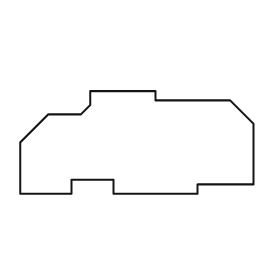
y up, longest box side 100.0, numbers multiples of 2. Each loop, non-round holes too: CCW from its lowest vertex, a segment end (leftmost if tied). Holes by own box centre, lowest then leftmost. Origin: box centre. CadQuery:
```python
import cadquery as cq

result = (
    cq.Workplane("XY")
    .moveTo(-50.0, -22.0)
    .lineTo(-28.0, -22.0)
    .lineTo(-28.0, -16.0)
    .lineTo(-10.0, -16.0)
    .lineTo(-10.0, -22.0)
    .lineTo(26.0, -22.0)
    .lineTo(26.0, -18.0)
    .lineTo(50.0, -18.0)
    .lineTo(50.0, 8.0)
    .lineTo(40.0, 18.0)
    .lineTo(8.0, 18.0)
    .lineTo(8.0, 22.0)
    .lineTo(-20.0, 22.0)
    .lineTo(-20.0, 16.0)
    .lineTo(-24.0, 12.0)
    .lineTo(-38.0, 12.0)
    .lineTo(-50.0, 0.0)
    .close()
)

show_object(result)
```